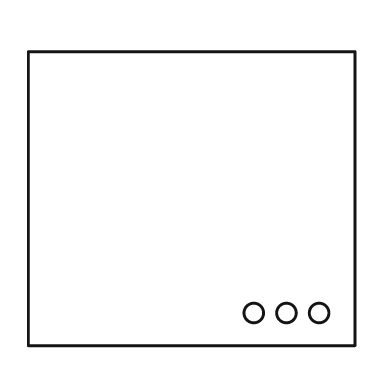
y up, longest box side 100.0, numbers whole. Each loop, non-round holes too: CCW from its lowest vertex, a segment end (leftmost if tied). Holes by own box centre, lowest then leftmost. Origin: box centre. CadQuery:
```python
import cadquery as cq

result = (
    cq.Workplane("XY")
    .moveTo(-50.0, -45.0)
    .lineTo(50.0, -45.0)
    .lineTo(50.0, 45.0)
    .lineTo(-50.0, 45.0)
    .close()
    .moveTo(19.0, -35.0)
    .circle(3.0)
    .moveTo(29.0, -35.0)
    .circle(3.0)
    .moveTo(39.0, -35.0)
    .circle(3.0)
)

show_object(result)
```